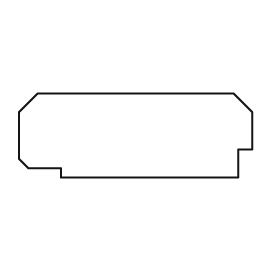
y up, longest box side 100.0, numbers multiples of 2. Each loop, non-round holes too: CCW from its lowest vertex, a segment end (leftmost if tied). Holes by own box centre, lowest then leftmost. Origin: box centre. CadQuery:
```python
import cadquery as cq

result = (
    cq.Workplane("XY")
    .moveTo(-32.0, -18.0)
    .lineTo(44.0, -18.0)
    .lineTo(44.0, -6.0)
    .lineTo(50.0, -6.0)
    .lineTo(50.0, 10.0)
    .lineTo(42.0, 18.0)
    .lineTo(-42.0, 18.0)
    .lineTo(-50.0, 10.0)
    .lineTo(-50.0, -10.0)
    .lineTo(-46.0, -14.0)
    .lineTo(-32.0, -14.0)
    .close()
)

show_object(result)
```